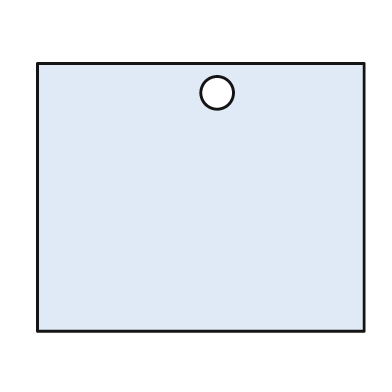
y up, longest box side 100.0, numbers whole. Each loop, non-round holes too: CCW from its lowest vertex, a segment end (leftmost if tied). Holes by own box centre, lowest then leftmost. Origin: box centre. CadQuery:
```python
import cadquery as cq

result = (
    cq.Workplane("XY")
    .moveTo(-50.0, -41.0)
    .lineTo(50.0, -41.0)
    .lineTo(50.0, 41.0)
    .lineTo(-50.0, 41.0)
    .close()
    .moveTo(5.0, 32.0)
    .circle(5.0)
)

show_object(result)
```